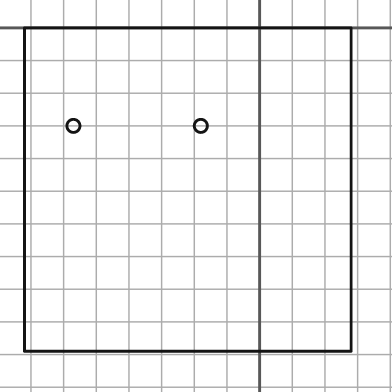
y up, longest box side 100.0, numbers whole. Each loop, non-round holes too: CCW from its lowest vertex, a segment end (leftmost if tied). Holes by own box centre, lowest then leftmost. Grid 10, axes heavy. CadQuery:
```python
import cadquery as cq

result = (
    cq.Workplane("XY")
    .moveTo(-72.0, -99.0)
    .lineTo(28.0, -99.0)
    .lineTo(28.0, 0.0)
    .lineTo(-72.0, 0.0)
    .close()
    .moveTo(-57.0, -30.0)
    .circle(2.0)
    .moveTo(-18.0, -30.0)
    .circle(2.0)
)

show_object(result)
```